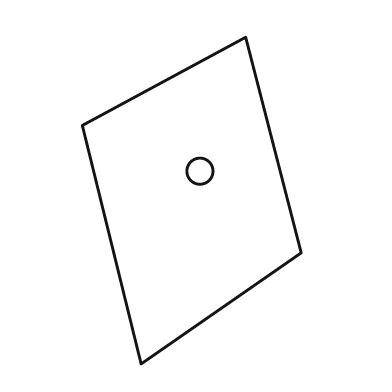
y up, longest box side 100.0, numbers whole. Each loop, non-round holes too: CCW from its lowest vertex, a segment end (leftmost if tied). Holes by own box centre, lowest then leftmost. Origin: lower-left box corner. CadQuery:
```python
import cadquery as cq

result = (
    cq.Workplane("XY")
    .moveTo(18.0, 0.0)
    .lineTo(67.0, 34.0)
    .lineTo(50.0, 100.0)
    .lineTo(0.0, 73.0)
    .close()
    .moveTo(36.0, 59.0)
    .circle(4.0)
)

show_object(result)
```